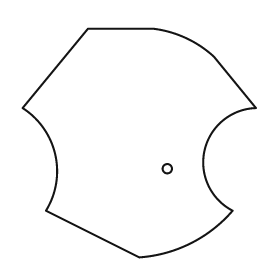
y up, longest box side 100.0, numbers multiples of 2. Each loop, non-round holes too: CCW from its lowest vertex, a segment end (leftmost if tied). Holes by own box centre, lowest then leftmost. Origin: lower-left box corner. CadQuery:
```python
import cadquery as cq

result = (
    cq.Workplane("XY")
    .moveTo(50.0, 0.0)
    .threePointArc((72.0, 6.0), (90.0, 20.0))
    .threePointArc((78.0, 46.0), (100.0, 64.0))
    .lineTo(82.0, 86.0)
    .threePointArc((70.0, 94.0), (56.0, 98.0))
    .lineTo(28.0, 98.0)
    .lineTo(0.0, 64.0)
    .threePointArc((14.0, 44.0), (10.0, 20.0))
    .close()
    .moveTo(62.0, 38.0)
    .circle(2.0)
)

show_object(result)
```